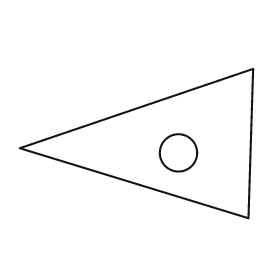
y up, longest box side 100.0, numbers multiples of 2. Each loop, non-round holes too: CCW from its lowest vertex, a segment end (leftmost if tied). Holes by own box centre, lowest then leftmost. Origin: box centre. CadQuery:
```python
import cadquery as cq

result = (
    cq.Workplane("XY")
    .moveTo(48.0, -32.0)
    .lineTo(50.0, 32.0)
    .lineTo(-50.0, -2.0)
    .close()
    .moveTo(18.0, -4.0)
    .circle(8.0)
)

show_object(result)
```